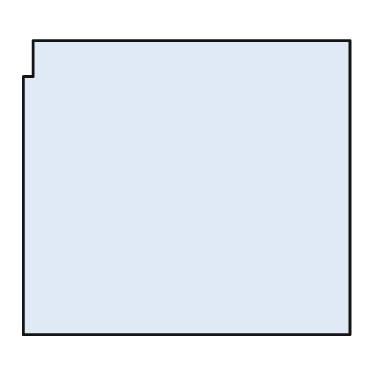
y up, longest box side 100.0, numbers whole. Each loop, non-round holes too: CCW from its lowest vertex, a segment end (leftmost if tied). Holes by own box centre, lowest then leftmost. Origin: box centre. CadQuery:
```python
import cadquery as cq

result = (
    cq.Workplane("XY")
    .moveTo(-50.0, -45.0)
    .lineTo(50.0, -45.0)
    .lineTo(50.0, 45.0)
    .lineTo(-47.0, 45.0)
    .lineTo(-47.0, 34.0)
    .lineTo(-50.0, 34.0)
    .close()
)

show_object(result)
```